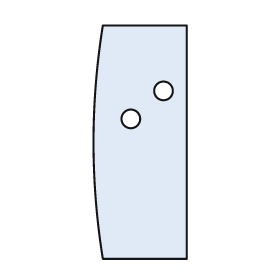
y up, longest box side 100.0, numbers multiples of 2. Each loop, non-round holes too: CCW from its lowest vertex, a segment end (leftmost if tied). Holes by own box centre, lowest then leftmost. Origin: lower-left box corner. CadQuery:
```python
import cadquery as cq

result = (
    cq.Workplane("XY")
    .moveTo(4.0, 0.0)
    .lineTo(40.0, 0.0)
    .lineTo(40.0, 100.0)
    .lineTo(4.0, 100.0)
    .threePointArc((0.0, 50.0), (4.0, 0.0))
    .close()
    .moveTo(16.0, 60.0)
    .circle(4.0)
    .moveTo(30.0, 72.0)
    .circle(4.0)
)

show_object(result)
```